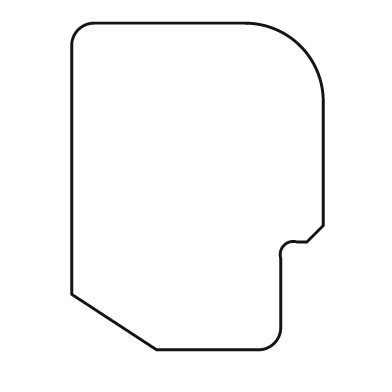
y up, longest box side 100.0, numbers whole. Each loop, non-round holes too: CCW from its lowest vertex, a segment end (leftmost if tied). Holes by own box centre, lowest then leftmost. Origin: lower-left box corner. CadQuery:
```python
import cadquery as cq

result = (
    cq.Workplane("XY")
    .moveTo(26.0, 0.0)
    .lineTo(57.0, 0.0)
    .threePointArc((62.0, 2.0), (64.0, 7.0))
    .lineTo(64.0, 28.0)
    .threePointArc((65.0, 32.0), (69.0, 33.0))
    .lineTo(72.0, 33.0)
    .lineTo(77.0, 38.0)
    .lineTo(77.0, 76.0)
    .threePointArc((70.0, 93.0), (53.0, 100.0))
    .lineTo(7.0, 100.0)
    .threePointArc((2.0, 98.0), (0.0, 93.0))
    .lineTo(0.0, 17.0)
    .close()
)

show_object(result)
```